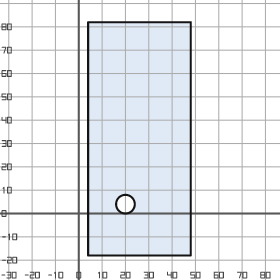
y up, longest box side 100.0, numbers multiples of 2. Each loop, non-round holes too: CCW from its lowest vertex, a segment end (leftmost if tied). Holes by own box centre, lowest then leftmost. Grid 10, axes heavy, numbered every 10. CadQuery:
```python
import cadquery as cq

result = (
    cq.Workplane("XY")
    .moveTo(4.0, -18.0)
    .lineTo(48.0, -18.0)
    .lineTo(48.0, 82.0)
    .lineTo(4.0, 82.0)
    .close()
    .moveTo(20.0, 4.0)
    .circle(4.0)
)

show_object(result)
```